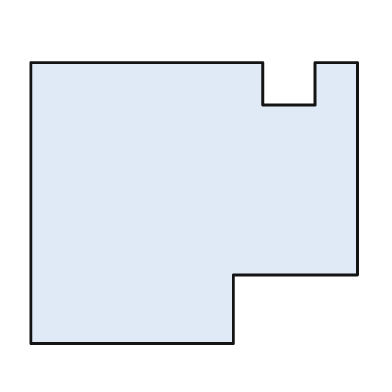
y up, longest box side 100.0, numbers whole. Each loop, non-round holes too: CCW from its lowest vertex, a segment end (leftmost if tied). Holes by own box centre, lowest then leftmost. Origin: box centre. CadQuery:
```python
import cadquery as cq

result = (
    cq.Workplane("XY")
    .moveTo(-50.0, -43.0)
    .lineTo(12.0, -43.0)
    .lineTo(12.0, -22.0)
    .lineTo(50.0, -22.0)
    .lineTo(50.0, 43.0)
    .lineTo(37.0, 43.0)
    .lineTo(37.0, 30.0)
    .lineTo(21.0, 30.0)
    .lineTo(21.0, 43.0)
    .lineTo(-50.0, 43.0)
    .close()
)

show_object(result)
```